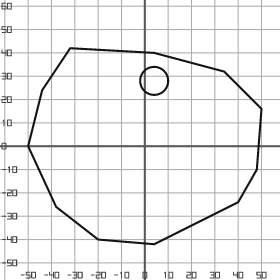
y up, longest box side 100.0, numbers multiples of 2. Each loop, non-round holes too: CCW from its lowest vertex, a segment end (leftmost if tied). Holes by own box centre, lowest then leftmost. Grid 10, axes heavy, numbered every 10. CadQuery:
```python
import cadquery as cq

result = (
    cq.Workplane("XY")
    .moveTo(4.0, -42.0)
    .lineTo(40.0, -24.0)
    .lineTo(48.0, -10.0)
    .lineTo(50.0, 16.0)
    .lineTo(34.0, 32.0)
    .lineTo(4.0, 40.0)
    .lineTo(-32.0, 42.0)
    .lineTo(-44.0, 24.0)
    .lineTo(-50.0, 0.0)
    .lineTo(-38.0, -26.0)
    .lineTo(-20.0, -40.0)
    .close()
    .moveTo(4.0, 28.0)
    .circle(6.0)
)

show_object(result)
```